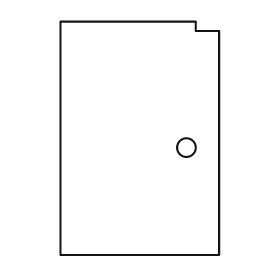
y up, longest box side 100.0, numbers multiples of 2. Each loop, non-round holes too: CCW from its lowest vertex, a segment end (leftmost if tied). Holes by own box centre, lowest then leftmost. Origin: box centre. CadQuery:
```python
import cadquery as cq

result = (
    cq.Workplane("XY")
    .moveTo(-34.0, -50.0)
    .lineTo(34.0, -50.0)
    .lineTo(34.0, 46.0)
    .lineTo(24.0, 46.0)
    .lineTo(24.0, 50.0)
    .lineTo(-34.0, 50.0)
    .close()
    .moveTo(20.0, -4.0)
    .circle(4.0)
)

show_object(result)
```